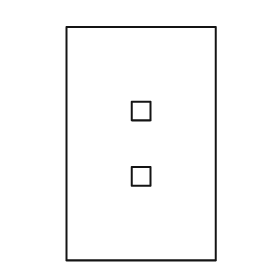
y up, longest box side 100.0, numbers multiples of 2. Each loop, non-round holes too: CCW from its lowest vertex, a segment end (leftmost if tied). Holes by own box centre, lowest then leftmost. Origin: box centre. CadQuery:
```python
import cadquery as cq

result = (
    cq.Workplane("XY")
    .moveTo(-32.0, -50.0)
    .lineTo(32.0, -50.0)
    .lineTo(32.0, 50.0)
    .lineTo(-32.0, 50.0)
    .close()
    .moveTo(-4.0, -18.0)
    .lineTo(4.0, -18.0)
    .lineTo(4.0, -10.0)
    .lineTo(-4.0, -10.0)
    .close()
    .moveTo(-4.0, 10.0)
    .lineTo(4.0, 10.0)
    .lineTo(4.0, 18.0)
    .lineTo(-4.0, 18.0)
    .close()
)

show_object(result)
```